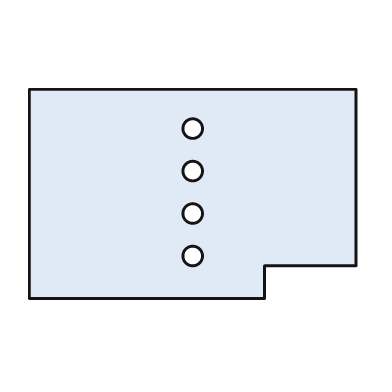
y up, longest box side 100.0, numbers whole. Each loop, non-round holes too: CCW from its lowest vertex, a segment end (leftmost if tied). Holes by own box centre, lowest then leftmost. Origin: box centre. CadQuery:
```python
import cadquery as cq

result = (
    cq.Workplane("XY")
    .moveTo(-50.0, -32.0)
    .lineTo(22.0, -32.0)
    .lineTo(22.0, -22.0)
    .lineTo(50.0, -22.0)
    .lineTo(50.0, 32.0)
    .lineTo(-50.0, 32.0)
    .close()
    .moveTo(0.0, -19.0)
    .circle(3.0)
    .moveTo(0.0, -6.0)
    .circle(3.0)
    .moveTo(0.0, 7.0)
    .circle(3.0)
    .moveTo(0.0, 20.0)
    .circle(3.0)
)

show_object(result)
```